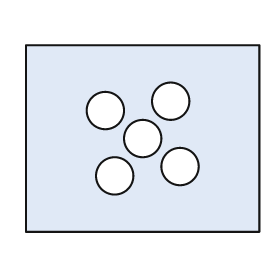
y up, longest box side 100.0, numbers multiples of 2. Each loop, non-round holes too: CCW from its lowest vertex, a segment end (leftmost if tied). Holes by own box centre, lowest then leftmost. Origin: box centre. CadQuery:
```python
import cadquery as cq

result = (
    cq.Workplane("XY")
    .moveTo(-50.0, -40.0)
    .lineTo(50.0, -40.0)
    .lineTo(50.0, 40.0)
    .lineTo(-50.0, 40.0)
    .close()
    .moveTo(-12.0, -16.0)
    .circle(8.0)
    .moveTo(16.0, -12.0)
    .circle(8.0)
    .moveTo(0.0, 0.0)
    .circle(8.0)
    .moveTo(-16.0, 12.0)
    .circle(8.0)
    .moveTo(12.0, 16.0)
    .circle(8.0)
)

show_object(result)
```